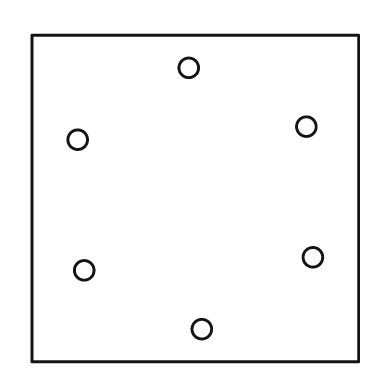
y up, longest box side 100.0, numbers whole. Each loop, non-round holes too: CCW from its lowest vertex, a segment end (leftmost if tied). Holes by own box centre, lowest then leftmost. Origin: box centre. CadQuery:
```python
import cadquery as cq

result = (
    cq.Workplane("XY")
    .moveTo(-50.0, -50.0)
    .lineTo(50.0, -50.0)
    .lineTo(50.0, 50.0)
    .lineTo(-50.0, 50.0)
    .close()
    .moveTo(2.0, -40.0)
    .circle(3.0)
    .moveTo(-34.0, -22.0)
    .circle(3.0)
    .moveTo(36.0, -18.0)
    .circle(3.0)
    .moveTo(-36.0, 18.0)
    .circle(3.0)
    .moveTo(34.0, 22.0)
    .circle(3.0)
    .moveTo(-2.0, 40.0)
    .circle(3.0)
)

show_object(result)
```